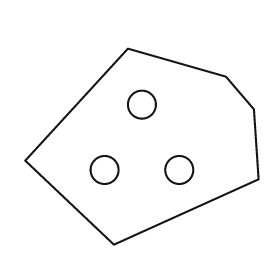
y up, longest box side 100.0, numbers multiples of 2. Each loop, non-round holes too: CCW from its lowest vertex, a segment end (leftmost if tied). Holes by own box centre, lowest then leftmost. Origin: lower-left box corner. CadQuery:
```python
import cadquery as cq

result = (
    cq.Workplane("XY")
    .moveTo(38.0, 0.0)
    .lineTo(100.0, 28.0)
    .lineTo(98.0, 58.0)
    .lineTo(86.0, 72.0)
    .lineTo(44.0, 84.0)
    .lineTo(0.0, 36.0)
    .close()
    .moveTo(34.0, 32.0)
    .circle(6.0)
    .moveTo(66.0, 32.0)
    .circle(6.0)
    .moveTo(50.0, 60.0)
    .circle(6.0)
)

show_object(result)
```